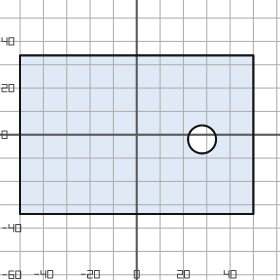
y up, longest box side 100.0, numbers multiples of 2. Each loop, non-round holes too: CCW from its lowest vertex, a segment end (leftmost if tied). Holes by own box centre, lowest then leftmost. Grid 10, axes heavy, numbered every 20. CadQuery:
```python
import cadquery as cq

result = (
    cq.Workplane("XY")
    .moveTo(-50.0, -34.0)
    .lineTo(50.0, -34.0)
    .lineTo(50.0, 34.0)
    .lineTo(-50.0, 34.0)
    .close()
    .moveTo(28.0, -2.0)
    .circle(6.0)
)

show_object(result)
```